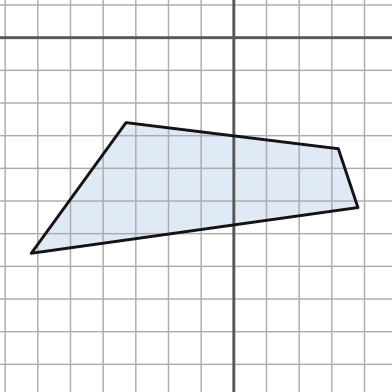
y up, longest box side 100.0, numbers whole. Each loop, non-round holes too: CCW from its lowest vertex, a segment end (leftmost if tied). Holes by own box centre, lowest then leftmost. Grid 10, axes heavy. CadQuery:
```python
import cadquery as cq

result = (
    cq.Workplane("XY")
    .moveTo(-62.0, -66.0)
    .lineTo(38.0, -52.0)
    .lineTo(32.0, -34.0)
    .lineTo(-33.0, -26.0)
    .close()
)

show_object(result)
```